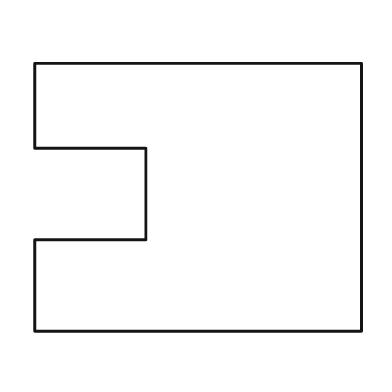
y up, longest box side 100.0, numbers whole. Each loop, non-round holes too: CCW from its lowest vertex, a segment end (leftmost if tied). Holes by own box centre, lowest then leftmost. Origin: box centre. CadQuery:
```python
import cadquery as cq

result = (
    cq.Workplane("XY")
    .moveTo(-50.0, -41.0)
    .lineTo(50.0, -41.0)
    .lineTo(50.0, 41.0)
    .lineTo(-50.0, 41.0)
    .lineTo(-50.0, 15.0)
    .lineTo(-16.0, 15.0)
    .lineTo(-16.0, -13.0)
    .lineTo(-50.0, -13.0)
    .close()
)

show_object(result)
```